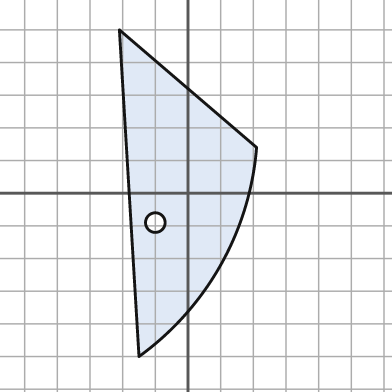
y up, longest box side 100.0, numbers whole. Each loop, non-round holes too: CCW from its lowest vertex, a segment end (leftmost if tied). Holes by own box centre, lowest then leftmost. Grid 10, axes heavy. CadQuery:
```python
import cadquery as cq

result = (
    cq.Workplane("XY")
    .moveTo(-15.0, -50.0)
    .threePointArc((10.0, -22.0), (21.0, 14.0))
    .lineTo(-21.0, 50.0)
    .close()
    .moveTo(-10.0, -9.0)
    .circle(3.0)
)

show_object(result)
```